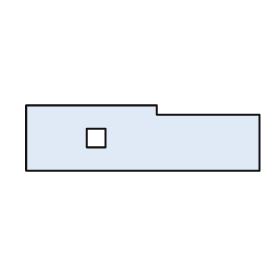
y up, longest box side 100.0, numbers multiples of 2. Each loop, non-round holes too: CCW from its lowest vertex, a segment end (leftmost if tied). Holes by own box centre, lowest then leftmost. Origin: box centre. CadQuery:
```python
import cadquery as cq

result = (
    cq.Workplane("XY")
    .moveTo(-50.0, -14.0)
    .lineTo(50.0, -14.0)
    .lineTo(50.0, 10.0)
    .lineTo(6.0, 10.0)
    .lineTo(6.0, 14.0)
    .lineTo(-50.0, 14.0)
    .close()
    .moveTo(-24.0, -4.0)
    .lineTo(-16.0, -4.0)
    .lineTo(-16.0, 4.0)
    .lineTo(-24.0, 4.0)
    .close()
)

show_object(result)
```